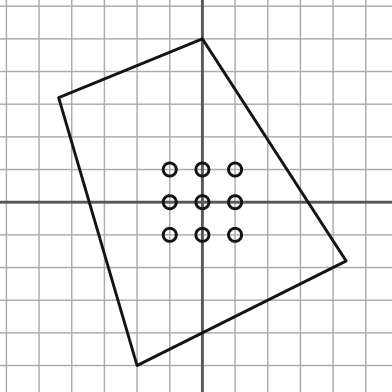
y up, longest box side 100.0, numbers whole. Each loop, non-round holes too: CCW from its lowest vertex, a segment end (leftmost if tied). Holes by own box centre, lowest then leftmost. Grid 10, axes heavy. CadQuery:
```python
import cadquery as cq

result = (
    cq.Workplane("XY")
    .moveTo(-20.0, -50.0)
    .lineTo(44.0, -18.0)
    .lineTo(0.0, 50.0)
    .lineTo(-44.0, 32.0)
    .close()
    .moveTo(-10.0, -10.0)
    .circle(2.0)
    .moveTo(0.0, -10.0)
    .circle(2.0)
    .moveTo(10.0, -10.0)
    .circle(2.0)
    .moveTo(-10.0, 0.0)
    .circle(2.0)
    .moveTo(0.0, 0.0)
    .circle(2.0)
    .moveTo(10.0, 0.0)
    .circle(2.0)
    .moveTo(-10.0, 10.0)
    .circle(2.0)
    .moveTo(0.0, 10.0)
    .circle(2.0)
    .moveTo(10.0, 10.0)
    .circle(2.0)
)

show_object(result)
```